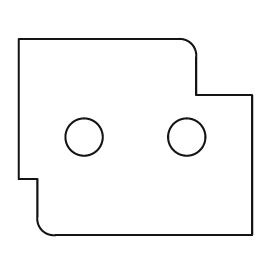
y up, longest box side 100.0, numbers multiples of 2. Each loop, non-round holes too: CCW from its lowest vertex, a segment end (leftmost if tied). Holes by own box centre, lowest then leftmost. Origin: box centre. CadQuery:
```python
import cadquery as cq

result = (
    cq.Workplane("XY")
    .moveTo(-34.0, -42.0)
    .lineTo(50.0, -42.0)
    .lineTo(50.0, 18.0)
    .lineTo(26.0, 18.0)
    .lineTo(26.0, 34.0)
    .threePointArc((24.0, 40.0), (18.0, 42.0))
    .lineTo(-50.0, 42.0)
    .lineTo(-50.0, -18.0)
    .lineTo(-42.0, -18.0)
    .lineTo(-42.0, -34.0)
    .threePointArc((-40.0, -40.0), (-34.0, -42.0))
    .close()
    .moveTo(-22.0, 0.0)
    .circle(8.0)
    .moveTo(22.0, 0.0)
    .circle(8.0)
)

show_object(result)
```